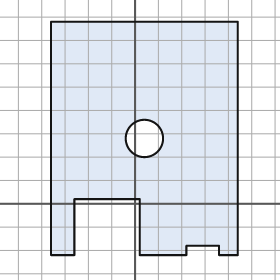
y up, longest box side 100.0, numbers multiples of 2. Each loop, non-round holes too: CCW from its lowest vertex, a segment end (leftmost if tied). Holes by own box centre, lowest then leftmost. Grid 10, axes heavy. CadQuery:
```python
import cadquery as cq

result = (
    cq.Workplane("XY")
    .moveTo(-36.0, -22.0)
    .lineTo(-26.0, -22.0)
    .lineTo(-26.0, 2.0)
    .lineTo(2.0, 2.0)
    .lineTo(2.0, -22.0)
    .lineTo(22.0, -22.0)
    .lineTo(22.0, -18.0)
    .lineTo(36.0, -18.0)
    .lineTo(36.0, -22.0)
    .lineTo(44.0, -22.0)
    .lineTo(44.0, 78.0)
    .lineTo(-36.0, 78.0)
    .close()
    .moveTo(4.0, 28.0)
    .circle(8.0)
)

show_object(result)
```